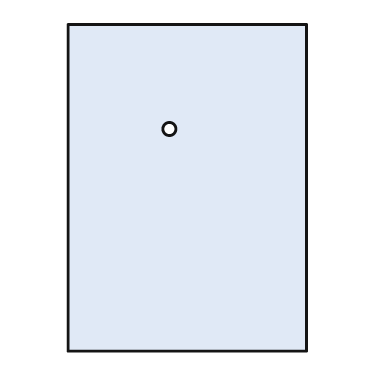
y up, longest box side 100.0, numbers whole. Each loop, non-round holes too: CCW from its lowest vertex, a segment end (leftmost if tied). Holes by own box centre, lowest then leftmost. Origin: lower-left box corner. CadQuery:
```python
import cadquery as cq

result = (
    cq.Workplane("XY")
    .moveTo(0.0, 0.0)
    .lineTo(73.0, 0.0)
    .lineTo(73.0, 100.0)
    .lineTo(0.0, 100.0)
    .close()
    .moveTo(31.0, 68.0)
    .circle(2.0)
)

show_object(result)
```